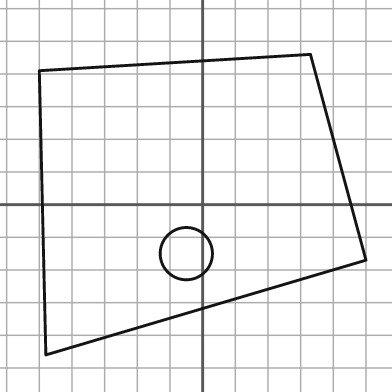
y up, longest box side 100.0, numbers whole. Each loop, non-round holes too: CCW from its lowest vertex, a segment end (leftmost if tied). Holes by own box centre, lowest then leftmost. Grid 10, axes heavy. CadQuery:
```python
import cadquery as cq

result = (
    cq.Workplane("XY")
    .moveTo(-48.0, -46.0)
    .lineTo(50.0, -17.0)
    .lineTo(33.0, 46.0)
    .lineTo(-50.0, 41.0)
    .close()
    .moveTo(-5.0, -15.0)
    .circle(8.0)
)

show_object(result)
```